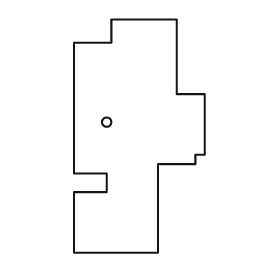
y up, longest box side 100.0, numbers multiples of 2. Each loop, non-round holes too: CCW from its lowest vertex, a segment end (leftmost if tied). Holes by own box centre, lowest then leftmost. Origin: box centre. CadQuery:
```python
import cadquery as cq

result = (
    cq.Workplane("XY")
    .moveTo(-28.0, -50.0)
    .lineTo(8.0, -50.0)
    .lineTo(8.0, -12.0)
    .lineTo(24.0, -12.0)
    .lineTo(24.0, -8.0)
    .lineTo(28.0, -8.0)
    .lineTo(28.0, 18.0)
    .lineTo(16.0, 18.0)
    .lineTo(16.0, 50.0)
    .lineTo(-12.0, 50.0)
    .lineTo(-12.0, 40.0)
    .lineTo(-28.0, 40.0)
    .lineTo(-28.0, -16.0)
    .lineTo(-14.0, -16.0)
    .lineTo(-14.0, -24.0)
    .lineTo(-28.0, -24.0)
    .close()
    .moveTo(-14.0, 6.0)
    .circle(2.0)
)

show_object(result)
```